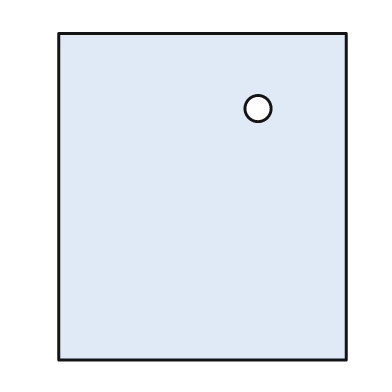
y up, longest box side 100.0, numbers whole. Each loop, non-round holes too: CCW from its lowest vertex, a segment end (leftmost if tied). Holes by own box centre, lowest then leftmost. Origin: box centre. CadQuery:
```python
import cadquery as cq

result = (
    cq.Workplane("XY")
    .moveTo(-44.0, -50.0)
    .lineTo(44.0, -50.0)
    .lineTo(44.0, 50.0)
    .lineTo(-44.0, 50.0)
    .close()
    .moveTo(17.0, 27.0)
    .circle(4.0)
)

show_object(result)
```